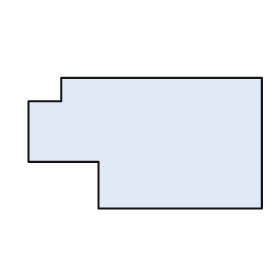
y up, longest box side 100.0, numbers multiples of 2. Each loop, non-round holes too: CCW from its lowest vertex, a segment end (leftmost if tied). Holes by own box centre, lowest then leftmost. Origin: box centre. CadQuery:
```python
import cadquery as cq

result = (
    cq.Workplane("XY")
    .moveTo(-20.0, -28.0)
    .lineTo(50.0, -28.0)
    .lineTo(50.0, 28.0)
    .lineTo(-36.0, 28.0)
    .lineTo(-36.0, 18.0)
    .lineTo(-50.0, 18.0)
    .lineTo(-50.0, -8.0)
    .lineTo(-20.0, -8.0)
    .close()
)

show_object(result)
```